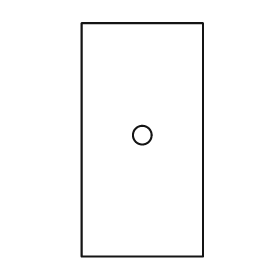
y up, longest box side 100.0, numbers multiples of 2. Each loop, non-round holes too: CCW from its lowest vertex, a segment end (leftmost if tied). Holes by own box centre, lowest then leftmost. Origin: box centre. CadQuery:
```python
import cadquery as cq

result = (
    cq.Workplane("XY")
    .moveTo(-26.0, -50.0)
    .lineTo(26.0, -50.0)
    .lineTo(26.0, 50.0)
    .lineTo(-26.0, 50.0)
    .close()
    .moveTo(0.0, 2.0)
    .circle(4.0)
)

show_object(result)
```